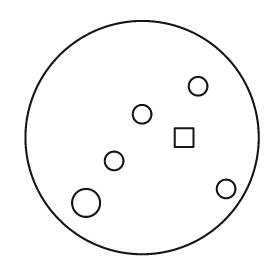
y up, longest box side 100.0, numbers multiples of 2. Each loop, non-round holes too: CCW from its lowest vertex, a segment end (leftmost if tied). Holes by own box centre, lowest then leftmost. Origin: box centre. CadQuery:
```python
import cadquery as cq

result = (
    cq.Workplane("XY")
    .moveTo(0.0, 0.0)
    .circle(50.0)
    .moveTo(-24.0, -28.0)
    .circle(6.0)
    .moveTo(36.0, -22.0)
    .circle(4.0)
    .moveTo(-12.0, -10.0)
    .circle(4.0)
    .moveTo(14.0, -4.0)
    .lineTo(22.0, -4.0)
    .lineTo(22.0, 4.0)
    .lineTo(14.0, 4.0)
    .close()
    .moveTo(0.0, 10.0)
    .circle(4.0)
    .moveTo(24.0, 22.0)
    .circle(4.0)
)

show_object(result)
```